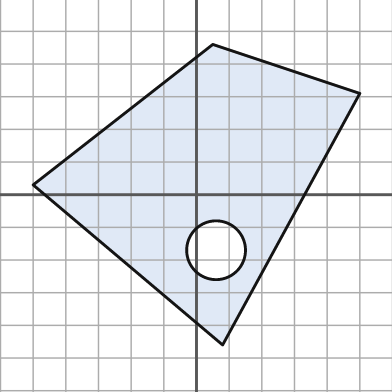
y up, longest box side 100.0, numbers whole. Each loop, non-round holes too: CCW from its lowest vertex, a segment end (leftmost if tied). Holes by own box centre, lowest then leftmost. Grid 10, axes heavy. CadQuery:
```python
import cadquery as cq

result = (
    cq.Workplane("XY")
    .moveTo(8.0, -46.0)
    .lineTo(50.0, 31.0)
    .lineTo(5.0, 46.0)
    .lineTo(-50.0, 3.0)
    .close()
    .moveTo(6.0, -17.0)
    .circle(9.0)
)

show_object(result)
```